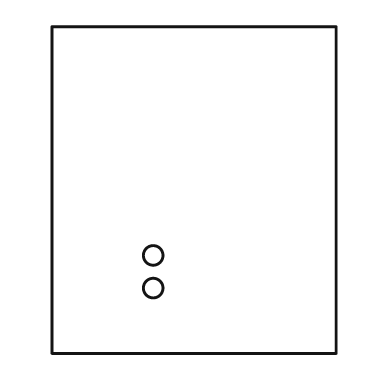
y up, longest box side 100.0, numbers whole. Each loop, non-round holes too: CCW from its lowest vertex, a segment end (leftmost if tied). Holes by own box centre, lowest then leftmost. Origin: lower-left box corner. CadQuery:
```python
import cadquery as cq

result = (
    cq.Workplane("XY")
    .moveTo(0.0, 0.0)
    .lineTo(87.0, 0.0)
    .lineTo(87.0, 100.0)
    .lineTo(0.0, 100.0)
    .close()
    .moveTo(31.0, 20.0)
    .circle(3.0)
    .moveTo(31.0, 30.0)
    .circle(3.0)
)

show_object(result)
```